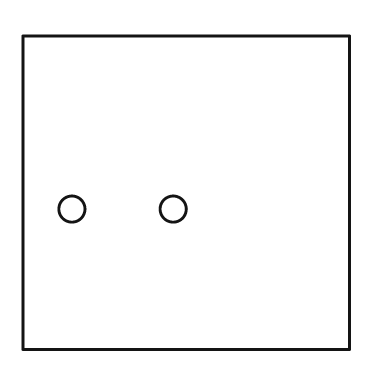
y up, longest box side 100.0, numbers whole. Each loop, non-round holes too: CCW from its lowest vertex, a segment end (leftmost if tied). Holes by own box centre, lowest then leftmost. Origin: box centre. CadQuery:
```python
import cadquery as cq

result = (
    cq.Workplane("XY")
    .moveTo(-50.0, -48.0)
    .lineTo(50.0, -48.0)
    .lineTo(50.0, 48.0)
    .lineTo(-50.0, 48.0)
    .close()
    .moveTo(-35.0, -5.0)
    .circle(4.0)
    .moveTo(-4.0, -5.0)
    .circle(4.0)
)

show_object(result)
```